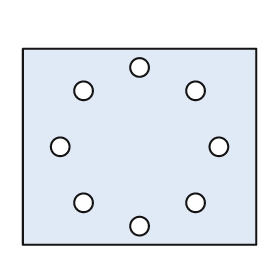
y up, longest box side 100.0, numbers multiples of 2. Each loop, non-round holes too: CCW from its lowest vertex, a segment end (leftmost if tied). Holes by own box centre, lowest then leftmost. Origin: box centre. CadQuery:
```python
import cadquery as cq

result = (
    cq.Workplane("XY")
    .moveTo(-50.0, -42.0)
    .lineTo(50.0, -42.0)
    .lineTo(50.0, 42.0)
    .lineTo(-50.0, 42.0)
    .close()
    .moveTo(0.0, -34.0)
    .circle(4.0)
    .moveTo(-24.0, -24.0)
    .circle(4.0)
    .moveTo(24.0, -24.0)
    .circle(4.0)
    .moveTo(-34.0, 0.0)
    .circle(4.0)
    .moveTo(34.0, 0.0)
    .circle(4.0)
    .moveTo(-24.0, 24.0)
    .circle(4.0)
    .moveTo(24.0, 24.0)
    .circle(4.0)
    .moveTo(0.0, 34.0)
    .circle(4.0)
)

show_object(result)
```